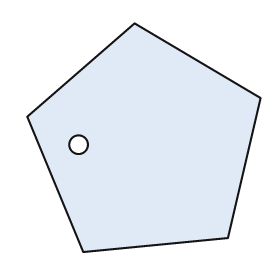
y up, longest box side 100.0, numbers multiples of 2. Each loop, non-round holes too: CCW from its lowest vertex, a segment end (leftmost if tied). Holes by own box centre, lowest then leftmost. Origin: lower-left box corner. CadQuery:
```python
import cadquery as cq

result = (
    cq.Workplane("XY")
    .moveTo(24.0, 0.0)
    .lineTo(86.0, 6.0)
    .lineTo(100.0, 66.0)
    .lineTo(46.0, 98.0)
    .lineTo(0.0, 58.0)
    .close()
    .moveTo(22.0, 46.0)
    .circle(4.0)
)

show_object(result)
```